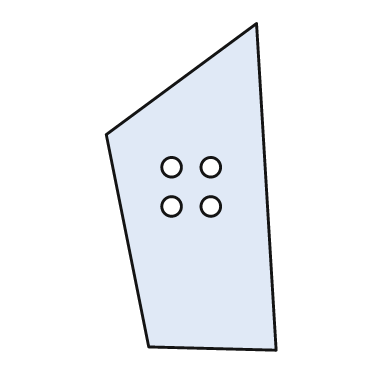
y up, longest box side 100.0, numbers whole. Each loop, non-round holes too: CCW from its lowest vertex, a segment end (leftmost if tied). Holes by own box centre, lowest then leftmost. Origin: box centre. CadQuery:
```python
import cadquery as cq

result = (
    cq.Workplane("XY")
    .moveTo(26.0, -50.0)
    .lineTo(20.0, 50.0)
    .lineTo(-26.0, 16.0)
    .lineTo(-13.0, -49.0)
    .close()
    .moveTo(-6.0, -6.0)
    .circle(3.0)
    .moveTo(6.0, -6.0)
    .circle(3.0)
    .moveTo(-6.0, 6.0)
    .circle(3.0)
    .moveTo(6.0, 6.0)
    .circle(3.0)
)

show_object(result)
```